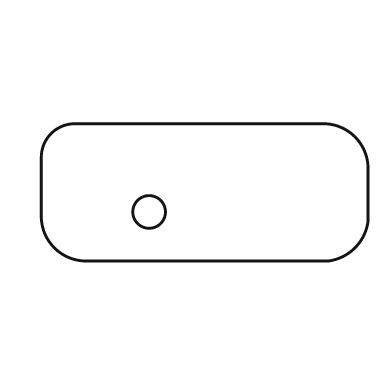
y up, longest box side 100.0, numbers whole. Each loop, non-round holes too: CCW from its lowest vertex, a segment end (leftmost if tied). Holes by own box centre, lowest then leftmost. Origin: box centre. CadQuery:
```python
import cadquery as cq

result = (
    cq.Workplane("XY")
    .moveTo(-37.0, -21.0)
    .lineTo(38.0, -21.0)
    .threePointArc((46.0, -17.0), (50.0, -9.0))
    .lineTo(50.0, 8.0)
    .threePointArc((46.0, 17.0), (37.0, 21.0))
    .lineTo(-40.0, 21.0)
    .threePointArc((-47.0, 18.0), (-50.0, 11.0))
    .lineTo(-50.0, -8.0)
    .threePointArc((-46.0, -17.0), (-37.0, -21.0))
    .close()
    .moveTo(-17.0, -6.0)
    .circle(5.0)
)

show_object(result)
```